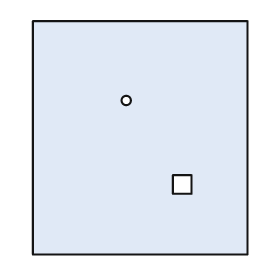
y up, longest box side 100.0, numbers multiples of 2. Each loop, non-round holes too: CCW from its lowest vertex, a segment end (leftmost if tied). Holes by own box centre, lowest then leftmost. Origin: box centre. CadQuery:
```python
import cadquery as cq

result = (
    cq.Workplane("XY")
    .moveTo(-46.0, -50.0)
    .lineTo(46.0, -50.0)
    .lineTo(46.0, 50.0)
    .lineTo(-46.0, 50.0)
    .close()
    .moveTo(14.0, -24.0)
    .lineTo(22.0, -24.0)
    .lineTo(22.0, -16.0)
    .lineTo(14.0, -16.0)
    .close()
    .moveTo(-6.0, 16.0)
    .circle(2.0)
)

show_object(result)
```